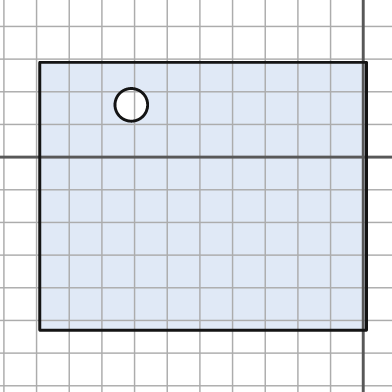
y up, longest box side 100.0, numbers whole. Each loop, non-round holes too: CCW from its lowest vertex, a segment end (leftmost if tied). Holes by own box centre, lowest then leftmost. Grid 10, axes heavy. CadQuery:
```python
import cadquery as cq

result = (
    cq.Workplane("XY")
    .moveTo(-99.0, -53.0)
    .lineTo(1.0, -53.0)
    .lineTo(1.0, 29.0)
    .lineTo(-99.0, 29.0)
    .close()
    .moveTo(-71.0, 16.0)
    .circle(5.0)
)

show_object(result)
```